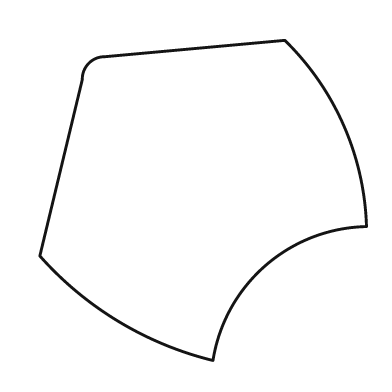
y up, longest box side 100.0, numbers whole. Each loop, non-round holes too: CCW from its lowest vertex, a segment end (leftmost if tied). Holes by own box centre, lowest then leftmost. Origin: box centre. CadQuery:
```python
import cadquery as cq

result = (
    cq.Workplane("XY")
    .moveTo(3.0, -49.0)
    .threePointArc((19.0, -20.0), (50.0, -8.0))
    .threePointArc((43.0, 23.0), (25.0, 49.0))
    .lineTo(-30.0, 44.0)
    .threePointArc((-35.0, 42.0), (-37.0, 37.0))
    .lineTo(-50.0, -17.0)
    .threePointArc((-26.0, -37.0), (3.0, -49.0))
    .close()
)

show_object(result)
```